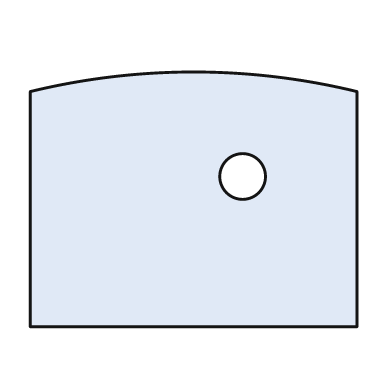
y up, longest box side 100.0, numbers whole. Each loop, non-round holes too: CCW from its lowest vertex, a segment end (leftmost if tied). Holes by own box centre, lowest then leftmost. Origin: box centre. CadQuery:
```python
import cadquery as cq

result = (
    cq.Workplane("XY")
    .moveTo(-50.0, -39.0)
    .lineTo(50.0, -39.0)
    .lineTo(50.0, 33.0)
    .threePointArc((0.0, 39.0), (-50.0, 33.0))
    .close()
    .moveTo(15.0, 7.0)
    .circle(7.0)
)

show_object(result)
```